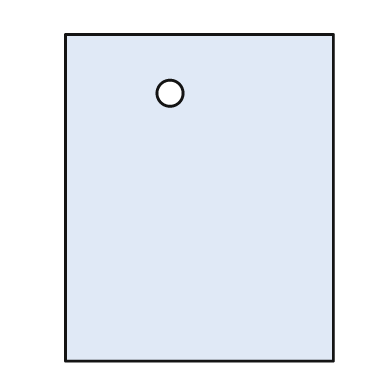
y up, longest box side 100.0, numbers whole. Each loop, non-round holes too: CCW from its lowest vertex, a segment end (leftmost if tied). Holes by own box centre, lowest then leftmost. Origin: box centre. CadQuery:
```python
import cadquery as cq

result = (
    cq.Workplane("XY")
    .moveTo(-41.0, -50.0)
    .lineTo(41.0, -50.0)
    .lineTo(41.0, 50.0)
    .lineTo(-41.0, 50.0)
    .close()
    .moveTo(-9.0, 32.0)
    .circle(4.0)
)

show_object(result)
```